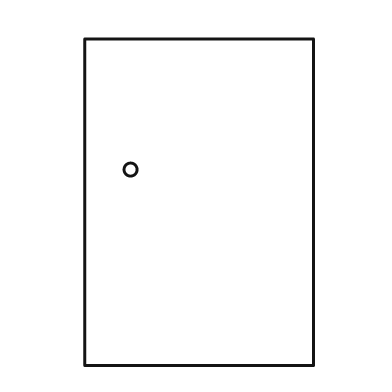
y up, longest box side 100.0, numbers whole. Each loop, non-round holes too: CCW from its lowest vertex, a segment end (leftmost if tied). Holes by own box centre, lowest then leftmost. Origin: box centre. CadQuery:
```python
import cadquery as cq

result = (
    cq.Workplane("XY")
    .moveTo(-35.0, -50.0)
    .lineTo(35.0, -50.0)
    .lineTo(35.0, 50.0)
    .lineTo(-35.0, 50.0)
    .close()
    .moveTo(-21.0, 10.0)
    .circle(2.0)
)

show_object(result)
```